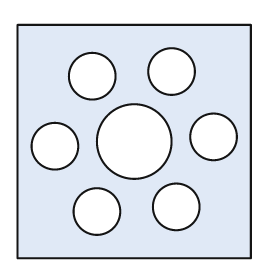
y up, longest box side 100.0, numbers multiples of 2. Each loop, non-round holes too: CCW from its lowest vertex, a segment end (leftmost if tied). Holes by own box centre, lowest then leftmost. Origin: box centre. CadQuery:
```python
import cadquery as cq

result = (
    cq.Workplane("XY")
    .moveTo(-50.0, -50.0)
    .lineTo(50.0, -50.0)
    .lineTo(50.0, 50.0)
    .lineTo(-50.0, 50.0)
    .close()
    .moveTo(-16.0, -30.0)
    .circle(10.0)
    .moveTo(18.0, -28.0)
    .circle(10.0)
    .moveTo(-34.0, -2.0)
    .circle(10.0)
    .moveTo(0.0, 0.0)
    .circle(16.0)
    .moveTo(34.0, 2.0)
    .circle(10.0)
    .moveTo(-18.0, 28.0)
    .circle(10.0)
    .moveTo(16.0, 30.0)
    .circle(10.0)
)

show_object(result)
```